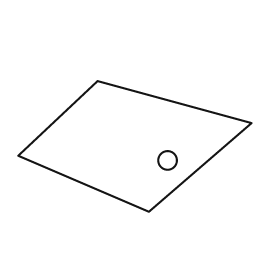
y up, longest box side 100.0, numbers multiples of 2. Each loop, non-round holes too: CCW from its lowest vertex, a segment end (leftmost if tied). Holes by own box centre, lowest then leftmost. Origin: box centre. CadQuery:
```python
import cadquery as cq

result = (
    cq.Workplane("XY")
    .moveTo(6.0, -28.0)
    .lineTo(50.0, 10.0)
    .lineTo(-16.0, 28.0)
    .lineTo(-50.0, -4.0)
    .close()
    .moveTo(14.0, -6.0)
    .circle(4.0)
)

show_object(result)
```